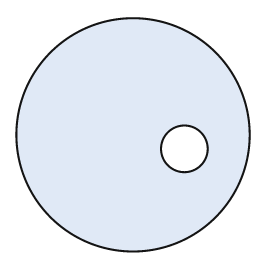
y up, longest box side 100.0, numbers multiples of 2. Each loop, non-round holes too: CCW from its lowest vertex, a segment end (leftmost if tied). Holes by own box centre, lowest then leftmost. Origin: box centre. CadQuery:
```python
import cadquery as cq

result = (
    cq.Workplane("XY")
    .moveTo(0.0, 0.0)
    .circle(50.0)
    .moveTo(22.0, -6.0)
    .circle(10.0)
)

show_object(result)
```